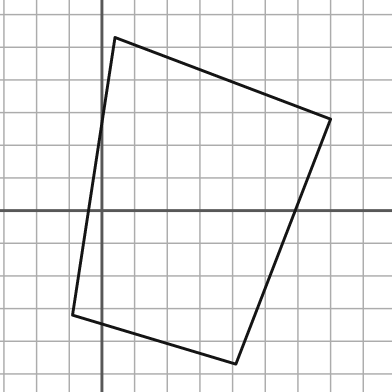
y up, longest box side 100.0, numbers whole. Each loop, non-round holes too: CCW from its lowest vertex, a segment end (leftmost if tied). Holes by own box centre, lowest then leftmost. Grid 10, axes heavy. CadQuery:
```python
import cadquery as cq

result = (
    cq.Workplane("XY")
    .moveTo(41.0, -47.0)
    .lineTo(70.0, 28.0)
    .lineTo(4.0, 53.0)
    .lineTo(-9.0, -32.0)
    .close()
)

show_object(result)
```